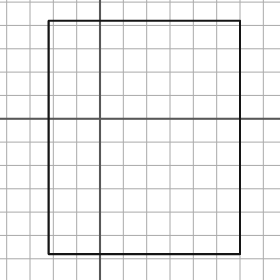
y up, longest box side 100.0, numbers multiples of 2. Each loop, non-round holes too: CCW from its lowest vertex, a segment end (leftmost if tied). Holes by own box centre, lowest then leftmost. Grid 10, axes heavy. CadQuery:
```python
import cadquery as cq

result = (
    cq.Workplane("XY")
    .moveTo(-22.0, -58.0)
    .lineTo(60.0, -58.0)
    .lineTo(60.0, 42.0)
    .lineTo(-22.0, 42.0)
    .close()
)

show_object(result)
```